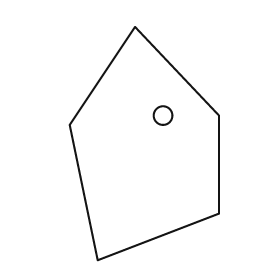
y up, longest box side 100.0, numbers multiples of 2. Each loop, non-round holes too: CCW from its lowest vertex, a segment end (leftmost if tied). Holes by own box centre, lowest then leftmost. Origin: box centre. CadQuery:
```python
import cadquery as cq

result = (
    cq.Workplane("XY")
    .moveTo(-20.0, -50.0)
    .lineTo(32.0, -30.0)
    .lineTo(32.0, 12.0)
    .lineTo(-4.0, 50.0)
    .lineTo(-32.0, 8.0)
    .close()
    .moveTo(8.0, 12.0)
    .circle(4.0)
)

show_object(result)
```